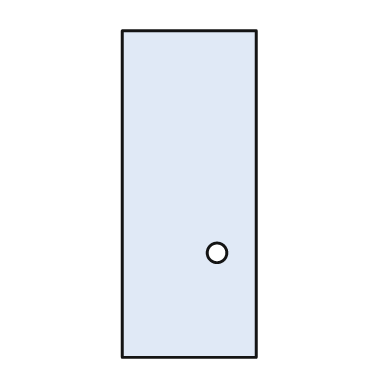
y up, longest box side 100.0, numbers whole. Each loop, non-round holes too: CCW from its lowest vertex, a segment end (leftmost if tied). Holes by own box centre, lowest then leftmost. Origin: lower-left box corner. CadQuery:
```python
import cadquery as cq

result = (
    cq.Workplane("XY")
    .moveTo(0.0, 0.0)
    .lineTo(41.0, 0.0)
    .lineTo(41.0, 100.0)
    .lineTo(0.0, 100.0)
    .close()
    .moveTo(29.0, 32.0)
    .circle(3.0)
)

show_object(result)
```